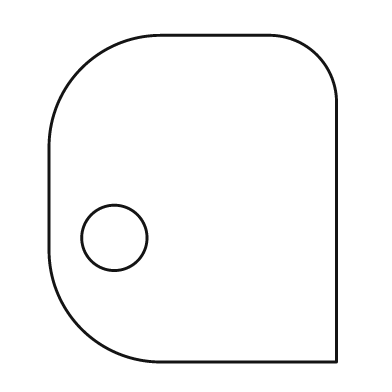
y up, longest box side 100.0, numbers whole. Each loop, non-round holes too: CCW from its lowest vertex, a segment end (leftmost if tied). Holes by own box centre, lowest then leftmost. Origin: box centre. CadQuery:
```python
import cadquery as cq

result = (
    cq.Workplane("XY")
    .moveTo(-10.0, -50.0)
    .lineTo(44.0, -50.0)
    .lineTo(44.0, 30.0)
    .threePointArc((38.0, 44.0), (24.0, 50.0))
    .lineTo(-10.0, 50.0)
    .threePointArc((-34.0, 40.0), (-44.0, 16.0))
    .lineTo(-44.0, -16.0)
    .threePointArc((-34.0, -40.0), (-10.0, -50.0))
    .close()
    .moveTo(-24.0, -12.0)
    .circle(10.0)
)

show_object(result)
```